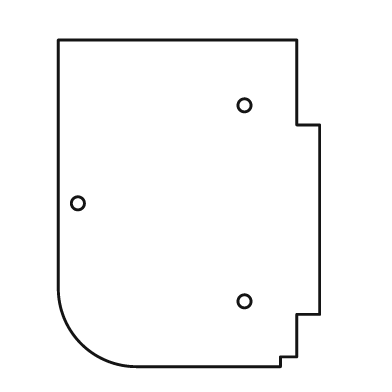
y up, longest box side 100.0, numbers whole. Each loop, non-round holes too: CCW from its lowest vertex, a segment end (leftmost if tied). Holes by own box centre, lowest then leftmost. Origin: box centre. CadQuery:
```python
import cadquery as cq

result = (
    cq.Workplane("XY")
    .moveTo(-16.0, -50.0)
    .lineTo(28.0, -50.0)
    .lineTo(28.0, -47.0)
    .lineTo(33.0, -47.0)
    .lineTo(33.0, -34.0)
    .lineTo(40.0, -34.0)
    .lineTo(40.0, 24.0)
    .lineTo(33.0, 24.0)
    .lineTo(33.0, 50.0)
    .lineTo(-40.0, 50.0)
    .lineTo(-40.0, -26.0)
    .threePointArc((-33.0, -43.0), (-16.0, -50.0))
    .close()
    .moveTo(17.0, -30.0)
    .circle(2.0)
    .moveTo(-34.0, 0.0)
    .circle(2.0)
    .moveTo(17.0, 30.0)
    .circle(2.0)
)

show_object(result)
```